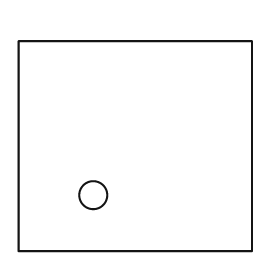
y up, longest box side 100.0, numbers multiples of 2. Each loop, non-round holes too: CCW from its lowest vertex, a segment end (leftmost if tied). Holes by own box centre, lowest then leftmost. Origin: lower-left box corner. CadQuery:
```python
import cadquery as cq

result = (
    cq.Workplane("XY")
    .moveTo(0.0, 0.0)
    .lineTo(100.0, 0.0)
    .lineTo(100.0, 90.0)
    .lineTo(0.0, 90.0)
    .close()
    .moveTo(32.0, 24.0)
    .circle(6.0)
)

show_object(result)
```